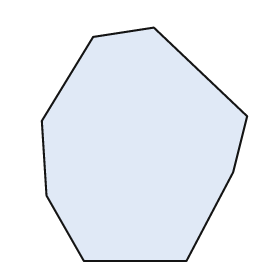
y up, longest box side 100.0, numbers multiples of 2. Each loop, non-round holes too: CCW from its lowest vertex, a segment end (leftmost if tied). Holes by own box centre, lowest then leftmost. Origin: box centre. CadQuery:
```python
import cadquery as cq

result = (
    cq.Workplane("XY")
    .moveTo(-26.0, -50.0)
    .lineTo(18.0, -50.0)
    .lineTo(38.0, -12.0)
    .lineTo(44.0, 12.0)
    .lineTo(4.0, 50.0)
    .lineTo(-22.0, 46.0)
    .lineTo(-44.0, 10.0)
    .lineTo(-42.0, -22.0)
    .close()
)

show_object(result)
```